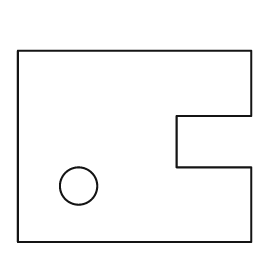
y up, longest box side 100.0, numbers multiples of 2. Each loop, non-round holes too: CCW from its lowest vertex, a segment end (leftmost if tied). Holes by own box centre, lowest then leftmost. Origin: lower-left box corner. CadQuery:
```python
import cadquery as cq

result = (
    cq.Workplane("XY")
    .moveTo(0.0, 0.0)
    .lineTo(100.0, 0.0)
    .lineTo(100.0, 32.0)
    .lineTo(68.0, 32.0)
    .lineTo(68.0, 54.0)
    .lineTo(100.0, 54.0)
    .lineTo(100.0, 82.0)
    .lineTo(0.0, 82.0)
    .close()
    .moveTo(26.0, 24.0)
    .circle(8.0)
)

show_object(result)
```